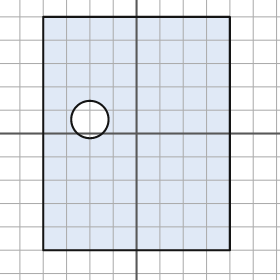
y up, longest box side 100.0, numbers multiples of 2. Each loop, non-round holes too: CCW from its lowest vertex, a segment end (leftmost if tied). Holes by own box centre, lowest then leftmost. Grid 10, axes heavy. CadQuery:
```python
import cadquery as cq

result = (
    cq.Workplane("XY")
    .moveTo(-40.0, -50.0)
    .lineTo(40.0, -50.0)
    .lineTo(40.0, 50.0)
    .lineTo(-40.0, 50.0)
    .close()
    .moveTo(-20.0, 6.0)
    .circle(8.0)
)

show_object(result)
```